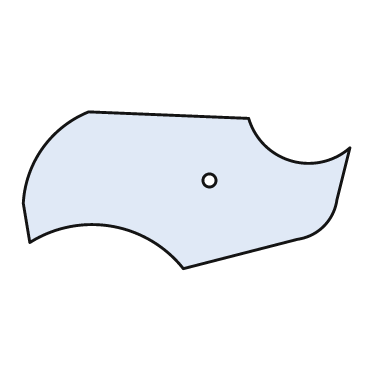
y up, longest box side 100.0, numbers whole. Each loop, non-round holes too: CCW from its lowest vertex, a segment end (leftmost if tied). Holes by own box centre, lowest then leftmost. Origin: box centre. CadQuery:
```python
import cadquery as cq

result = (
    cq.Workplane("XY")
    .moveTo(-1.0, -24.0)
    .lineTo(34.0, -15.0)
    .threePointArc((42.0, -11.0), (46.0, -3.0))
    .lineTo(50.0, 13.0)
    .threePointArc((32.0, 9.0), (19.0, 22.0))
    .lineTo(-30.0, 24.0)
    .threePointArc((-44.0, 13.0), (-50.0, -4.0))
    .lineTo(-48.0, -16.0)
    .threePointArc((-23.0, -11.0), (-1.0, -24.0))
    .close()
    .moveTo(7.0, 3.0)
    .circle(2.0)
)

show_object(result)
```